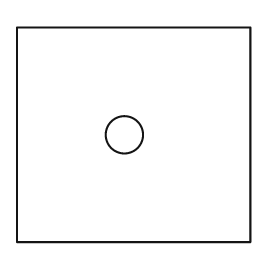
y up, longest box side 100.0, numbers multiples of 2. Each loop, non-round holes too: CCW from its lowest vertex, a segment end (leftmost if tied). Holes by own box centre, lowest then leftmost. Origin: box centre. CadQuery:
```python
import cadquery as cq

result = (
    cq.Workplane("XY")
    .moveTo(-50.0, -46.0)
    .lineTo(50.0, -46.0)
    .lineTo(50.0, 46.0)
    .lineTo(-50.0, 46.0)
    .close()
    .moveTo(-4.0, 0.0)
    .circle(8.0)
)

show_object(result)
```